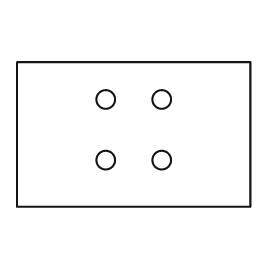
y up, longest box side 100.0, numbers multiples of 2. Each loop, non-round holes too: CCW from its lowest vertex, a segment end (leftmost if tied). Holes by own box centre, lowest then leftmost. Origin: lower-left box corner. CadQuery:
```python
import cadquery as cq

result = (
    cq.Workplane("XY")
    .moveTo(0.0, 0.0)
    .lineTo(100.0, 0.0)
    .lineTo(100.0, 62.0)
    .lineTo(0.0, 62.0)
    .close()
    .moveTo(38.0, 20.0)
    .circle(4.0)
    .moveTo(62.0, 20.0)
    .circle(4.0)
    .moveTo(38.0, 46.0)
    .circle(4.0)
    .moveTo(62.0, 46.0)
    .circle(4.0)
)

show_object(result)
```